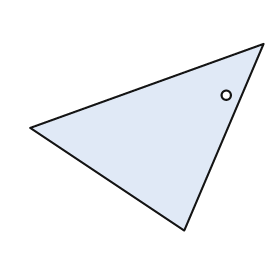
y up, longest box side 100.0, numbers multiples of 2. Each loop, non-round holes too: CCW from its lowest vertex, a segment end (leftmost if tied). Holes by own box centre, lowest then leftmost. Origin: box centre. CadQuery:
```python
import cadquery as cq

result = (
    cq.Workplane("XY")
    .moveTo(16.0, -40.0)
    .lineTo(50.0, 40.0)
    .lineTo(-50.0, 4.0)
    .close()
    .moveTo(34.0, 18.0)
    .circle(2.0)
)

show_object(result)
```